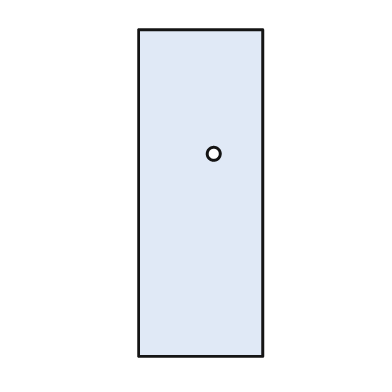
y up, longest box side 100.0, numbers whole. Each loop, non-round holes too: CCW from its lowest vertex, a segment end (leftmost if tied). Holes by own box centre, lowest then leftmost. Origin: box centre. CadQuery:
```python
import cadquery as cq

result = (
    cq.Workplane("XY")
    .moveTo(-19.0, -50.0)
    .lineTo(19.0, -50.0)
    .lineTo(19.0, 50.0)
    .lineTo(-19.0, 50.0)
    .close()
    .moveTo(4.0, 12.0)
    .circle(2.0)
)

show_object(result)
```